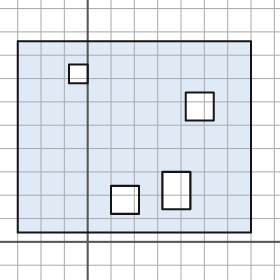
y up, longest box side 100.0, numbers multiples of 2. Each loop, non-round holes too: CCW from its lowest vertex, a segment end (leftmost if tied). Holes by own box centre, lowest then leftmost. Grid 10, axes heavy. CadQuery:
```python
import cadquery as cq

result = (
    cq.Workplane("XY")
    .moveTo(-30.0, 4.0)
    .lineTo(70.0, 4.0)
    .lineTo(70.0, 86.0)
    .lineTo(-30.0, 86.0)
    .close()
    .moveTo(10.0, 12.0)
    .lineTo(22.0, 12.0)
    .lineTo(22.0, 24.0)
    .lineTo(10.0, 24.0)
    .close()
    .moveTo(32.0, 14.0)
    .lineTo(44.0, 14.0)
    .lineTo(44.0, 30.0)
    .lineTo(32.0, 30.0)
    .close()
    .moveTo(42.0, 52.0)
    .lineTo(54.0, 52.0)
    .lineTo(54.0, 64.0)
    .lineTo(42.0, 64.0)
    .close()
    .moveTo(-8.0, 68.0)
    .lineTo(0.0, 68.0)
    .lineTo(0.0, 76.0)
    .lineTo(-8.0, 76.0)
    .close()
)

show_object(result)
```